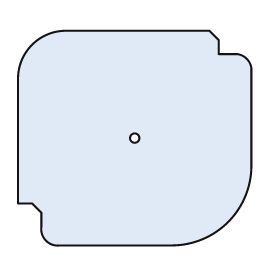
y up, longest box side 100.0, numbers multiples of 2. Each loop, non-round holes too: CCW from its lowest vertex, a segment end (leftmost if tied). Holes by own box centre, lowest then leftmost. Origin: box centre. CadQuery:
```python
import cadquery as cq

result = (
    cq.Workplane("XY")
    .moveTo(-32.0, -46.0)
    .lineTo(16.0, -46.0)
    .threePointArc((40.0, -36.0), (50.0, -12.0))
    .lineTo(50.0, 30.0)
    .threePointArc((48.0, 34.0), (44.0, 36.0))
    .lineTo(36.0, 36.0)
    .lineTo(36.0, 42.0)
    .lineTo(32.0, 46.0)
    .lineTo(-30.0, 46.0)
    .threePointArc((-44.0, 40.0), (-50.0, 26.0))
    .lineTo(-50.0, -28.0)
    .lineTo(-44.0, -28.0)
    .lineTo(-40.0, -32.0)
    .lineTo(-40.0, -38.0)
    .threePointArc((-38.0, -44.0), (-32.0, -46.0))
    .close()
    .moveTo(0.0, 0.0)
    .circle(2.0)
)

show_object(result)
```